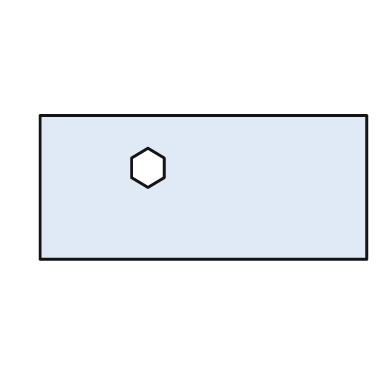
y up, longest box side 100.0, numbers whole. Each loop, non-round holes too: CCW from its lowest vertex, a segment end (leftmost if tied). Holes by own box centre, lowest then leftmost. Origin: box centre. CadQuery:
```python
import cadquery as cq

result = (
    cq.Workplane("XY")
    .moveTo(-50.0, -22.0)
    .lineTo(50.0, -22.0)
    .lineTo(50.0, 22.0)
    .lineTo(-50.0, 22.0)
    .close()
    .moveTo(-17.0, 0.0)
    .lineTo(-12.0, 3.0)
    .lineTo(-12.0, 9.0)
    .lineTo(-17.0, 12.0)
    .lineTo(-22.0, 9.0)
    .lineTo(-22.0, 3.0)
    .close()
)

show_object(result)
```